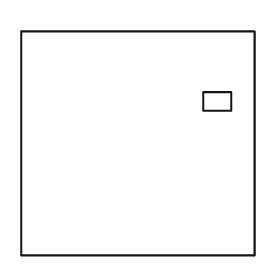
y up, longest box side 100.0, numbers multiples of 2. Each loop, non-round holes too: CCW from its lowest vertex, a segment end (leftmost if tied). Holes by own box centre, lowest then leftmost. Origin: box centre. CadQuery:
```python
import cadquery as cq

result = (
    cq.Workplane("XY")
    .moveTo(-50.0, -48.0)
    .lineTo(50.0, -48.0)
    .lineTo(50.0, 48.0)
    .lineTo(-50.0, 48.0)
    .close()
    .moveTo(28.0, 14.0)
    .lineTo(40.0, 14.0)
    .lineTo(40.0, 22.0)
    .lineTo(28.0, 22.0)
    .close()
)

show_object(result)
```